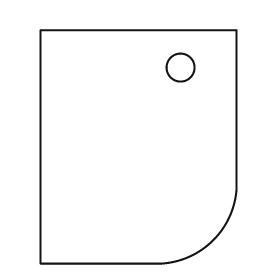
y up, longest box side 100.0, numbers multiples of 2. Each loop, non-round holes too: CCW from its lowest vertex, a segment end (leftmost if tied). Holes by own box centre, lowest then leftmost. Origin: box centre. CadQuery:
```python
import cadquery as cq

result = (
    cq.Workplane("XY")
    .moveTo(-42.0, -50.0)
    .lineTo(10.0, -50.0)
    .threePointArc((32.0, -40.0), (42.0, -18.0))
    .lineTo(42.0, 50.0)
    .lineTo(-42.0, 50.0)
    .close()
    .moveTo(18.0, 34.0)
    .circle(6.0)
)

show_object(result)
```